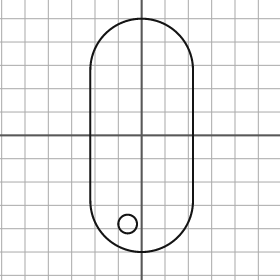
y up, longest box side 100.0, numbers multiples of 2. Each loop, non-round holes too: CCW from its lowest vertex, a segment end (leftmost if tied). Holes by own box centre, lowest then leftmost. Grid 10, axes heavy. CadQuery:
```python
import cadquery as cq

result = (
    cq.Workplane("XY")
    .moveTo(-22.0, -28.0)
    .threePointArc((0.0, -50.0), (22.0, -28.0))
    .lineTo(22.0, 28.0)
    .threePointArc((0.0, 50.0), (-22.0, 28.0))
    .close()
    .moveTo(-6.0, -38.0)
    .circle(4.0)
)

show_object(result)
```